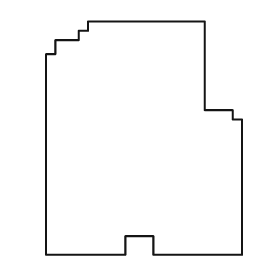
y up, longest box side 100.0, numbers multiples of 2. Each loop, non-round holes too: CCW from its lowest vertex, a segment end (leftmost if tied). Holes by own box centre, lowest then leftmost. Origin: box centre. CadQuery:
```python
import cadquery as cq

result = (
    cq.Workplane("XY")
    .moveTo(-42.0, -50.0)
    .lineTo(-8.0, -50.0)
    .lineTo(-8.0, -42.0)
    .lineTo(4.0, -42.0)
    .lineTo(4.0, -50.0)
    .lineTo(42.0, -50.0)
    .lineTo(42.0, 8.0)
    .lineTo(38.0, 8.0)
    .lineTo(38.0, 12.0)
    .lineTo(26.0, 12.0)
    .lineTo(26.0, 50.0)
    .lineTo(-24.0, 50.0)
    .lineTo(-24.0, 46.0)
    .lineTo(-28.0, 46.0)
    .lineTo(-28.0, 42.0)
    .lineTo(-38.0, 42.0)
    .lineTo(-38.0, 36.0)
    .lineTo(-42.0, 36.0)
    .close()
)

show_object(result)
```